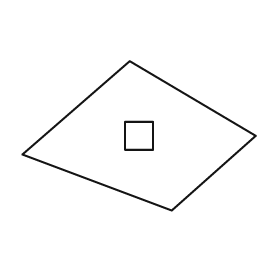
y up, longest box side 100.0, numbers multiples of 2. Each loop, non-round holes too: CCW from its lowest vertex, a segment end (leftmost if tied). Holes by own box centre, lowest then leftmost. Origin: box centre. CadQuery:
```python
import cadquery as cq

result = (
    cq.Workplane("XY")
    .moveTo(14.0, -32.0)
    .lineTo(50.0, 0.0)
    .lineTo(-4.0, 32.0)
    .lineTo(-50.0, -8.0)
    .close()
    .moveTo(-6.0, -6.0)
    .lineTo(6.0, -6.0)
    .lineTo(6.0, 6.0)
    .lineTo(-6.0, 6.0)
    .close()
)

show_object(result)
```